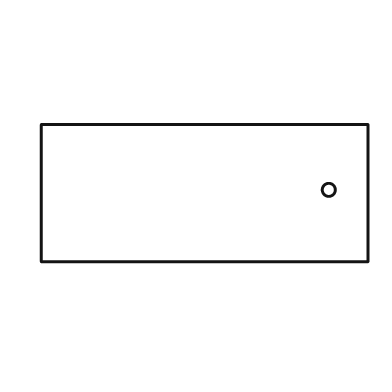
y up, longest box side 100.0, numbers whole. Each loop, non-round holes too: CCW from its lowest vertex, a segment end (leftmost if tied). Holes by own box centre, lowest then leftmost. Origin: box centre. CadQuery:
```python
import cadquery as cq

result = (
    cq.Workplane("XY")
    .moveTo(-50.0, -21.0)
    .lineTo(50.0, -21.0)
    .lineTo(50.0, 21.0)
    .lineTo(-50.0, 21.0)
    .close()
    .moveTo(38.0, 1.0)
    .circle(2.0)
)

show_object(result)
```